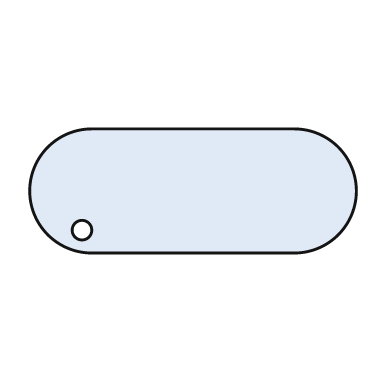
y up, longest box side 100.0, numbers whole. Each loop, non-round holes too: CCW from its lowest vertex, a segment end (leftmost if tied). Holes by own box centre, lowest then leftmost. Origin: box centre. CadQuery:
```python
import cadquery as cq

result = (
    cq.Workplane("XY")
    .moveTo(-31.0, -19.0)
    .lineTo(31.0, -19.0)
    .threePointArc((50.0, 0.0), (31.0, 19.0))
    .lineTo(-31.0, 19.0)
    .threePointArc((-50.0, 0.0), (-31.0, -19.0))
    .close()
    .moveTo(-34.0, -12.0)
    .circle(3.0)
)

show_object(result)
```